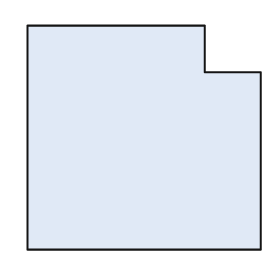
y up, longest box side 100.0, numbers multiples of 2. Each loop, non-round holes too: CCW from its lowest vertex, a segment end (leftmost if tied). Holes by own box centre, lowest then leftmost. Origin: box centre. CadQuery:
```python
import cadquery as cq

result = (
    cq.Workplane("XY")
    .moveTo(-50.0, -48.0)
    .lineTo(50.0, -48.0)
    .lineTo(50.0, 28.0)
    .lineTo(26.0, 28.0)
    .lineTo(26.0, 48.0)
    .lineTo(-50.0, 48.0)
    .close()
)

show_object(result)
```